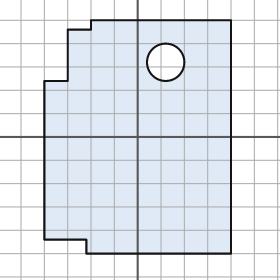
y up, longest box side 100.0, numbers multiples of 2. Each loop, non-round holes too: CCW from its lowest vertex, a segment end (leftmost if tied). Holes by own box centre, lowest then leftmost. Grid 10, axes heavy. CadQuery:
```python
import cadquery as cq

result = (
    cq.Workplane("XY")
    .moveTo(-22.0, -50.0)
    .lineTo(40.0, -50.0)
    .lineTo(40.0, 50.0)
    .lineTo(-20.0, 50.0)
    .lineTo(-20.0, 46.0)
    .lineTo(-30.0, 46.0)
    .lineTo(-30.0, 24.0)
    .lineTo(-40.0, 24.0)
    .lineTo(-40.0, -44.0)
    .lineTo(-22.0, -44.0)
    .close()
    .moveTo(12.0, 32.0)
    .circle(8.0)
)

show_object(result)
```